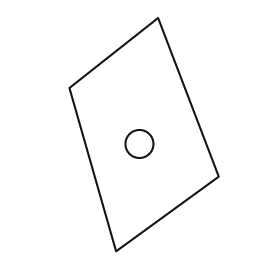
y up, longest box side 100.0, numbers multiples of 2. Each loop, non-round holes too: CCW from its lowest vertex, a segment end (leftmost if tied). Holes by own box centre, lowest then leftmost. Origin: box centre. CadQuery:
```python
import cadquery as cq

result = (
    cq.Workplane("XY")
    .moveTo(-12.0, -50.0)
    .lineTo(32.0, -18.0)
    .lineTo(6.0, 50.0)
    .lineTo(-32.0, 20.0)
    .close()
    .moveTo(-2.0, -4.0)
    .circle(6.0)
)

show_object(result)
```